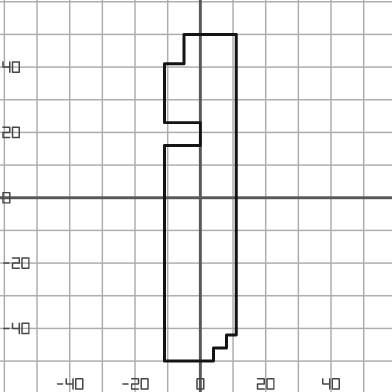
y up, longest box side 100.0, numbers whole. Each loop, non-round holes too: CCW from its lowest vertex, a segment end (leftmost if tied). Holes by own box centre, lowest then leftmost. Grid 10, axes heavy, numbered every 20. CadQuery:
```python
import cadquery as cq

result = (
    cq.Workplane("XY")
    .moveTo(-11.0, -50.0)
    .lineTo(4.0, -50.0)
    .lineTo(4.0, -46.0)
    .lineTo(8.0, -46.0)
    .lineTo(8.0, -42.0)
    .lineTo(11.0, -42.0)
    .lineTo(11.0, 50.0)
    .lineTo(-5.0, 50.0)
    .lineTo(-5.0, 41.0)
    .lineTo(-11.0, 41.0)
    .lineTo(-11.0, 23.0)
    .lineTo(0.0, 23.0)
    .lineTo(0.0, 16.0)
    .lineTo(-11.0, 16.0)
    .close()
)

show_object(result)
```